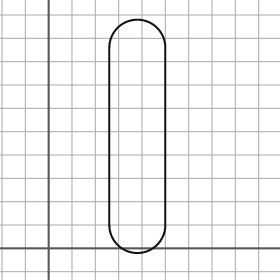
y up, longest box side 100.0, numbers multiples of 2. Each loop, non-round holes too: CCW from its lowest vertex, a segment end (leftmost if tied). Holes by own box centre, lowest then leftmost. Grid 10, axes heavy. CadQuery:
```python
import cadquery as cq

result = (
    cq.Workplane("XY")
    .moveTo(26.0, 10.0)
    .threePointArc((38.0, -2.0), (50.0, 10.0))
    .lineTo(50.0, 86.0)
    .threePointArc((38.0, 98.0), (26.0, 86.0))
    .close()
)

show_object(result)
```